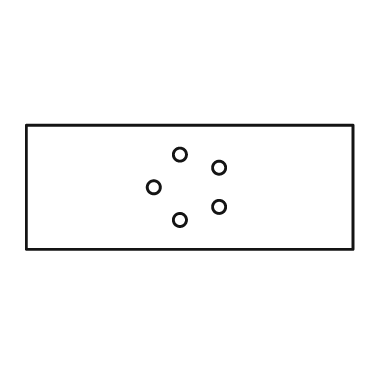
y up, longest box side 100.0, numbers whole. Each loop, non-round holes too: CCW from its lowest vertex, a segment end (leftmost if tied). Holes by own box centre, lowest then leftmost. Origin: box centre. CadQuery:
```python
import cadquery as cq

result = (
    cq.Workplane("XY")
    .moveTo(-50.0, -19.0)
    .lineTo(50.0, -19.0)
    .lineTo(50.0, 19.0)
    .lineTo(-50.0, 19.0)
    .close()
    .moveTo(-3.0, -10.0)
    .circle(2.0)
    .moveTo(9.0, -6.0)
    .circle(2.0)
    .moveTo(-11.0, 0.0)
    .circle(2.0)
    .moveTo(9.0, 6.0)
    .circle(2.0)
    .moveTo(-3.0, 10.0)
    .circle(2.0)
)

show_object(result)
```